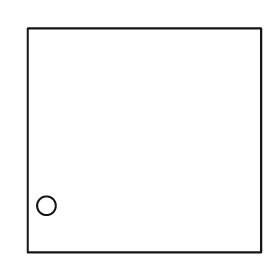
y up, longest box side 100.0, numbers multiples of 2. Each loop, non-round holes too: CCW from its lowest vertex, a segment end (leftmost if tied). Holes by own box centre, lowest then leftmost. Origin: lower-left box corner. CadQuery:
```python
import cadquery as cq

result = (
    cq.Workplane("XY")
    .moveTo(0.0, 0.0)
    .lineTo(100.0, 0.0)
    .lineTo(100.0, 96.0)
    .lineTo(0.0, 96.0)
    .close()
    .moveTo(8.0, 20.0)
    .circle(4.0)
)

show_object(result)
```